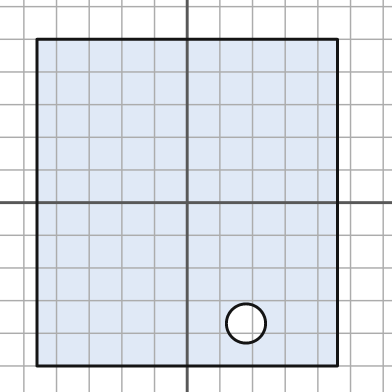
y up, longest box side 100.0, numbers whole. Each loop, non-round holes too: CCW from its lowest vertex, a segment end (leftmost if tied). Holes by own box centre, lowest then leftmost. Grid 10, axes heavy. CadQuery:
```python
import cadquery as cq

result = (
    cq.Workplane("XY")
    .moveTo(-46.0, -50.0)
    .lineTo(46.0, -50.0)
    .lineTo(46.0, 50.0)
    .lineTo(-46.0, 50.0)
    .close()
    .moveTo(18.0, -37.0)
    .circle(6.0)
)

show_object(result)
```